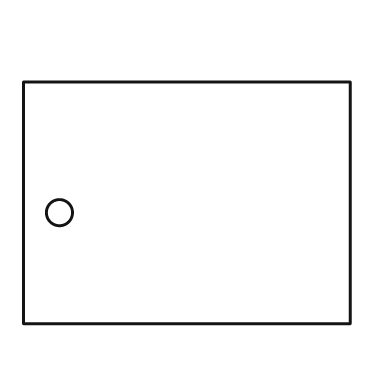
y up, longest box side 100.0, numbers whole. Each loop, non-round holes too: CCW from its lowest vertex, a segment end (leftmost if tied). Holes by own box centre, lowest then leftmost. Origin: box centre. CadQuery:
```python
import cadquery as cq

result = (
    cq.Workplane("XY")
    .moveTo(-50.0, -37.0)
    .lineTo(50.0, -37.0)
    .lineTo(50.0, 37.0)
    .lineTo(-50.0, 37.0)
    .close()
    .moveTo(-39.0, -3.0)
    .circle(4.0)
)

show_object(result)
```